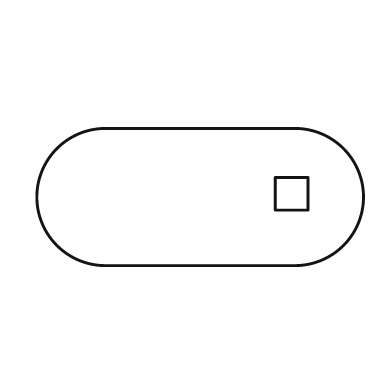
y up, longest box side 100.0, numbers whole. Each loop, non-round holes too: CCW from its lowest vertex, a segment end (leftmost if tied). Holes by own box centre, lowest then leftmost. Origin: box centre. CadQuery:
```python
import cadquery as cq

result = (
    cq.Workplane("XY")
    .moveTo(-29.0, -21.0)
    .lineTo(29.0, -21.0)
    .threePointArc((50.0, 0.0), (29.0, 21.0))
    .lineTo(-29.0, 21.0)
    .threePointArc((-50.0, 0.0), (-29.0, -21.0))
    .close()
    .moveTo(23.0, -4.0)
    .lineTo(33.0, -4.0)
    .lineTo(33.0, 6.0)
    .lineTo(23.0, 6.0)
    .close()
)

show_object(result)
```